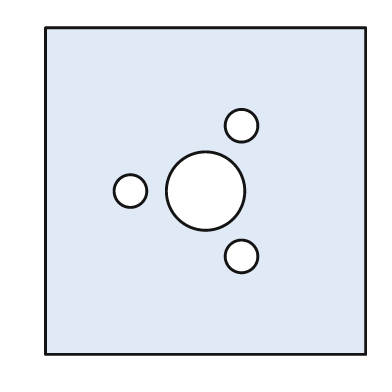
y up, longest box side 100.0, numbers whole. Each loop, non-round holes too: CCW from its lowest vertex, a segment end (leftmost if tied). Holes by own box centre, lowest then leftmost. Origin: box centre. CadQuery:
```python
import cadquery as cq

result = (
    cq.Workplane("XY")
    .moveTo(-49.0, -50.0)
    .lineTo(49.0, -50.0)
    .lineTo(49.0, 50.0)
    .lineTo(-49.0, 50.0)
    .close()
    .moveTo(11.0, -20.0)
    .circle(5.0)
    .moveTo(-23.0, 0.0)
    .circle(5.0)
    .moveTo(0.0, 0.0)
    .circle(12.0)
    .moveTo(11.0, 20.0)
    .circle(5.0)
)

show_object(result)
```